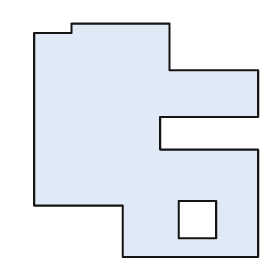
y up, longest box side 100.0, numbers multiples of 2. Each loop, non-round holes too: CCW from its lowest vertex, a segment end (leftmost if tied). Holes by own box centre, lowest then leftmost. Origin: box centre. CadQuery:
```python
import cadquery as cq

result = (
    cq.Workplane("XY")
    .moveTo(-10.0, -50.0)
    .lineTo(48.0, -50.0)
    .lineTo(48.0, -4.0)
    .lineTo(6.0, -4.0)
    .lineTo(6.0, 10.0)
    .lineTo(48.0, 10.0)
    .lineTo(48.0, 30.0)
    .lineTo(10.0, 30.0)
    .lineTo(10.0, 50.0)
    .lineTo(-32.0, 50.0)
    .lineTo(-32.0, 46.0)
    .lineTo(-48.0, 46.0)
    .lineTo(-48.0, -28.0)
    .lineTo(-10.0, -28.0)
    .close()
    .moveTo(14.0, -42.0)
    .lineTo(30.0, -42.0)
    .lineTo(30.0, -26.0)
    .lineTo(14.0, -26.0)
    .close()
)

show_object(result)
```